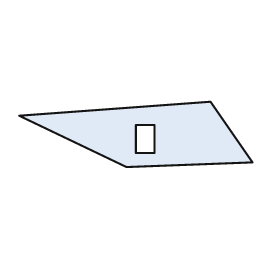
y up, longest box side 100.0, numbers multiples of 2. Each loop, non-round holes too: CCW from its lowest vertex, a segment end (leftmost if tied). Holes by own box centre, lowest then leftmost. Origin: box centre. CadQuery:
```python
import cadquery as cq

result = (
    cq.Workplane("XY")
    .moveTo(-4.0, -14.0)
    .lineTo(50.0, -12.0)
    .lineTo(32.0, 14.0)
    .lineTo(-50.0, 8.0)
    .close()
    .moveTo(0.0, -8.0)
    .lineTo(8.0, -8.0)
    .lineTo(8.0, 4.0)
    .lineTo(0.0, 4.0)
    .close()
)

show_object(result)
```